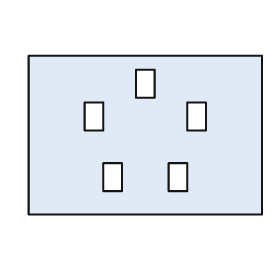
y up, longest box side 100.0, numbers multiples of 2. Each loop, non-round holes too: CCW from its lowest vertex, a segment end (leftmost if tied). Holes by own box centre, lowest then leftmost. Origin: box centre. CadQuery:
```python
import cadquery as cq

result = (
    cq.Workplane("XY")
    .moveTo(-50.0, -34.0)
    .lineTo(50.0, -34.0)
    .lineTo(50.0, 34.0)
    .lineTo(-50.0, 34.0)
    .close()
    .moveTo(-18.0, -24.0)
    .lineTo(-10.0, -24.0)
    .lineTo(-10.0, -12.0)
    .lineTo(-18.0, -12.0)
    .close()
    .moveTo(10.0, -24.0)
    .lineTo(18.0, -24.0)
    .lineTo(18.0, -12.0)
    .lineTo(10.0, -12.0)
    .close()
    .moveTo(-26.0, 2.0)
    .lineTo(-18.0, 2.0)
    .lineTo(-18.0, 14.0)
    .lineTo(-26.0, 14.0)
    .close()
    .moveTo(18.0, 2.0)
    .lineTo(26.0, 2.0)
    .lineTo(26.0, 14.0)
    .lineTo(18.0, 14.0)
    .close()
    .moveTo(-4.0, 16.0)
    .lineTo(4.0, 16.0)
    .lineTo(4.0, 28.0)
    .lineTo(-4.0, 28.0)
    .close()
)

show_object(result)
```